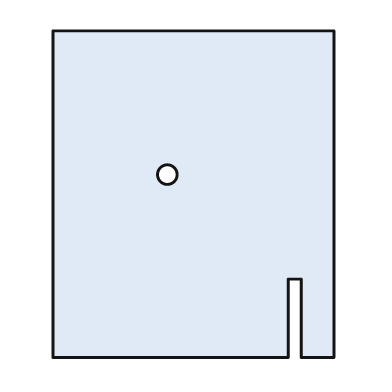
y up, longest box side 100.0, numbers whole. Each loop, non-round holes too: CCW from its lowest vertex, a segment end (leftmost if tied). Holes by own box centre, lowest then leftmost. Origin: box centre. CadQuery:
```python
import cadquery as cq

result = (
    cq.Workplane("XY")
    .moveTo(-43.0, -50.0)
    .lineTo(29.0, -50.0)
    .lineTo(29.0, -26.0)
    .lineTo(33.0, -26.0)
    .lineTo(33.0, -50.0)
    .lineTo(43.0, -50.0)
    .lineTo(43.0, 50.0)
    .lineTo(-43.0, 50.0)
    .close()
    .moveTo(-8.0, 6.0)
    .circle(3.0)
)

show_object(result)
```